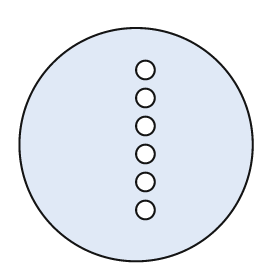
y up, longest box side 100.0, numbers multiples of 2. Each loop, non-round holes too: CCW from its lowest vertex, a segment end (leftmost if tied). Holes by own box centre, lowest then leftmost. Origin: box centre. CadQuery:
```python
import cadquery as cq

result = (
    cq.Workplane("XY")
    .moveTo(0.0, 0.0)
    .circle(50.0)
    .moveTo(4.0, -28.0)
    .circle(4.0)
    .moveTo(4.0, -16.0)
    .circle(4.0)
    .moveTo(4.0, -4.0)
    .circle(4.0)
    .moveTo(4.0, 8.0)
    .circle(4.0)
    .moveTo(4.0, 20.0)
    .circle(4.0)
    .moveTo(4.0, 32.0)
    .circle(4.0)
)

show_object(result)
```